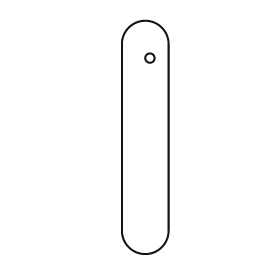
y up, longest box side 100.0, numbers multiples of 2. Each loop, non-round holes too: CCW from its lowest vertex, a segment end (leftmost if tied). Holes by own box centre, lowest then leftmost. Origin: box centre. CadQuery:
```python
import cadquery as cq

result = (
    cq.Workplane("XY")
    .moveTo(-10.0, -40.0)
    .threePointArc((0.0, -50.0), (10.0, -40.0))
    .lineTo(10.0, 40.0)
    .threePointArc((0.0, 50.0), (-10.0, 40.0))
    .close()
    .moveTo(2.0, 34.0)
    .circle(2.0)
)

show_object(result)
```